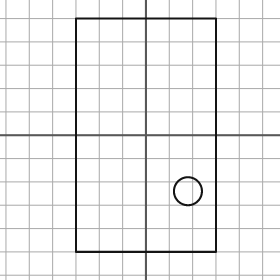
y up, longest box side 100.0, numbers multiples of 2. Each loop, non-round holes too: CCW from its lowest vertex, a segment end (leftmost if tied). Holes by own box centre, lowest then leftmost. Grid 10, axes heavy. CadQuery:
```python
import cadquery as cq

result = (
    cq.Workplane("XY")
    .moveTo(-30.0, -50.0)
    .lineTo(30.0, -50.0)
    .lineTo(30.0, 50.0)
    .lineTo(-30.0, 50.0)
    .close()
    .moveTo(18.0, -24.0)
    .circle(6.0)
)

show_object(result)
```